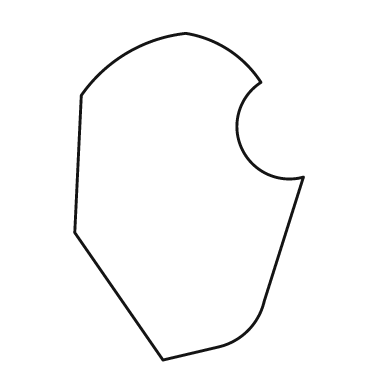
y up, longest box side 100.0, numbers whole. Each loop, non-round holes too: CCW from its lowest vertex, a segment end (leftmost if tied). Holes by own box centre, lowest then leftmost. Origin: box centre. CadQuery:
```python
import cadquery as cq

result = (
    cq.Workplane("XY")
    .moveTo(-8.0, -50.0)
    .lineTo(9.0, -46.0)
    .threePointArc((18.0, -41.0), (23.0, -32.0))
    .lineTo(35.0, 6.0)
    .threePointArc((16.0, 15.0), (22.0, 35.0))
    .threePointArc((12.0, 45.0), (-1.0, 50.0))
    .threePointArc((-19.0, 44.0), (-33.0, 31.0))
    .lineTo(-35.0, -11.0)
    .close()
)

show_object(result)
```